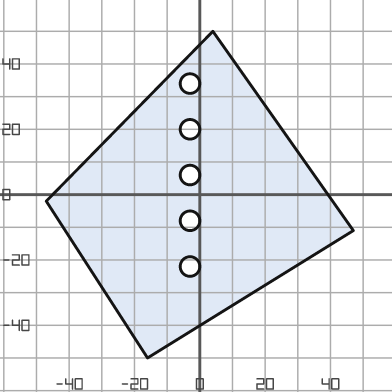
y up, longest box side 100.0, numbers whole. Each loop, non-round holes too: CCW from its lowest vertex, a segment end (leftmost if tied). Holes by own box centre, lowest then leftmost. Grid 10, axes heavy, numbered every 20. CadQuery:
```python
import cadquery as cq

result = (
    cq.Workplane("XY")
    .moveTo(-16.0, -50.0)
    .lineTo(47.0, -11.0)
    .lineTo(4.0, 50.0)
    .lineTo(-47.0, -2.0)
    .close()
    .moveTo(-3.0, -22.0)
    .circle(3.0)
    .moveTo(-3.0, -8.0)
    .circle(3.0)
    .moveTo(-3.0, 6.0)
    .circle(3.0)
    .moveTo(-3.0, 20.0)
    .circle(3.0)
    .moveTo(-3.0, 34.0)
    .circle(3.0)
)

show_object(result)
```